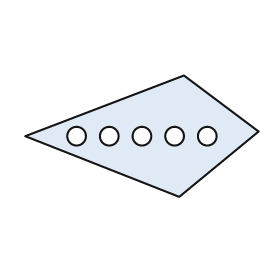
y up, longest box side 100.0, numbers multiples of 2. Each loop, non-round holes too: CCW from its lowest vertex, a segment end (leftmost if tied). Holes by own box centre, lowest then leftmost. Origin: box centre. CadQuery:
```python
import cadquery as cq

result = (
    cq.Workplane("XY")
    .moveTo(16.0, -26.0)
    .lineTo(50.0, 2.0)
    .lineTo(18.0, 26.0)
    .lineTo(-50.0, 0.0)
    .close()
    .moveTo(-28.0, 0.0)
    .circle(4.0)
    .moveTo(-14.0, 0.0)
    .circle(4.0)
    .moveTo(0.0, 0.0)
    .circle(4.0)
    .moveTo(14.0, 0.0)
    .circle(4.0)
    .moveTo(28.0, 0.0)
    .circle(4.0)
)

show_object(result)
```